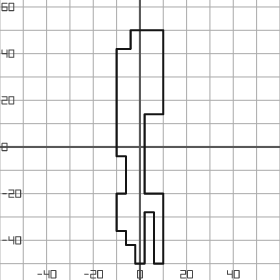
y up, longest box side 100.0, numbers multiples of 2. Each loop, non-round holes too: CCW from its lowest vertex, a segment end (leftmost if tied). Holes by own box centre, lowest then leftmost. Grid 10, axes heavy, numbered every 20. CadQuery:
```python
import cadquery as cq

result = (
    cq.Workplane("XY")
    .moveTo(-2.0, -50.0)
    .lineTo(2.0, -50.0)
    .lineTo(2.0, -28.0)
    .lineTo(6.0, -28.0)
    .lineTo(6.0, -50.0)
    .lineTo(10.0, -50.0)
    .lineTo(10.0, -20.0)
    .lineTo(2.0, -20.0)
    .lineTo(2.0, 14.0)
    .lineTo(10.0, 14.0)
    .lineTo(10.0, 50.0)
    .lineTo(-4.0, 50.0)
    .lineTo(-4.0, 42.0)
    .lineTo(-10.0, 42.0)
    .lineTo(-10.0, -4.0)
    .lineTo(-6.0, -4.0)
    .lineTo(-6.0, -20.0)
    .lineTo(-10.0, -20.0)
    .lineTo(-10.0, -36.0)
    .lineTo(-6.0, -36.0)
    .lineTo(-6.0, -42.0)
    .lineTo(-2.0, -42.0)
    .close()
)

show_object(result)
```